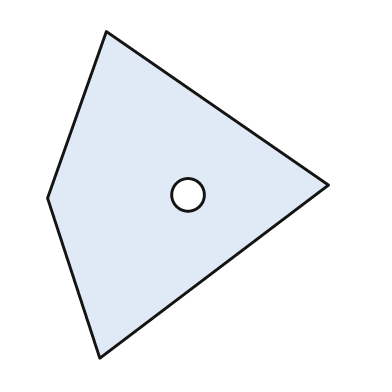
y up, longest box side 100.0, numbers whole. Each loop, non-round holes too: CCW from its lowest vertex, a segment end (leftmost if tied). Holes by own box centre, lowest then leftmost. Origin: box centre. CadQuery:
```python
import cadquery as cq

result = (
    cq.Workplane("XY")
    .moveTo(-27.0, -50.0)
    .lineTo(43.0, 3.0)
    .lineTo(-25.0, 50.0)
    .lineTo(-43.0, -1.0)
    .close()
    .moveTo(0.0, 0.0)
    .circle(5.0)
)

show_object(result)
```